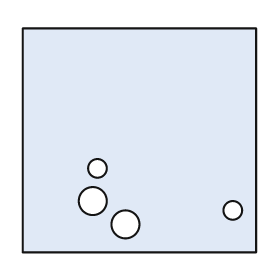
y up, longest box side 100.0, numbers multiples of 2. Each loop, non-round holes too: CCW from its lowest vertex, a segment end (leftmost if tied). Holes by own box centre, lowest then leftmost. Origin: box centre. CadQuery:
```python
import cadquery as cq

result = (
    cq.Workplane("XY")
    .moveTo(-50.0, -48.0)
    .lineTo(50.0, -48.0)
    .lineTo(50.0, 48.0)
    .lineTo(-50.0, 48.0)
    .close()
    .moveTo(-6.0, -36.0)
    .circle(6.0)
    .moveTo(40.0, -30.0)
    .circle(4.0)
    .moveTo(-20.0, -26.0)
    .circle(6.0)
    .moveTo(-18.0, -12.0)
    .circle(4.0)
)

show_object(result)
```